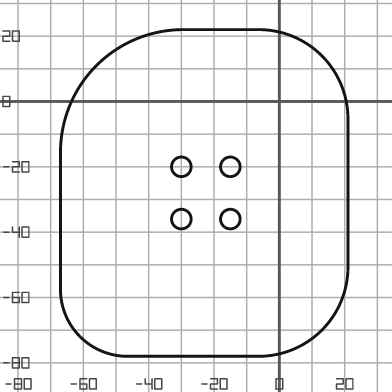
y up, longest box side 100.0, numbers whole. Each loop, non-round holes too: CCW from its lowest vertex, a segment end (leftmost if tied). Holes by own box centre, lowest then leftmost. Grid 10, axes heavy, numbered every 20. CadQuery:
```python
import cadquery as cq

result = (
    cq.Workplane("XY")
    .moveTo(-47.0, -78.0)
    .lineTo(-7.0, -78.0)
    .threePointArc((13.0, -70.0), (21.0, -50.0))
    .lineTo(21.0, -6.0)
    .threePointArc((13.0, 14.0), (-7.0, 22.0))
    .lineTo(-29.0, 22.0)
    .threePointArc((-56.0, 11.0), (-67.0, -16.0))
    .lineTo(-67.0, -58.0)
    .threePointArc((-61.0, -72.0), (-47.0, -78.0))
    .close()
    .moveTo(-30.0, -36.0)
    .circle(3.0)
    .moveTo(-15.0, -36.0)
    .circle(3.0)
    .moveTo(-30.0, -20.0)
    .circle(3.0)
    .moveTo(-15.0, -20.0)
    .circle(3.0)
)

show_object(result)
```